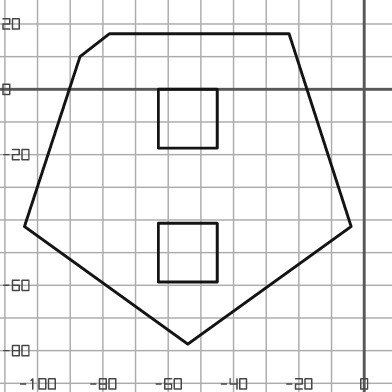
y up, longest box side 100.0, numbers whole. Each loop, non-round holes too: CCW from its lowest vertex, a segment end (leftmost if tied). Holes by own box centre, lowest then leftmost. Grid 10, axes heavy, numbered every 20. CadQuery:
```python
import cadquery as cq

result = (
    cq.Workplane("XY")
    .moveTo(-54.0, -78.0)
    .lineTo(-4.0, -42.0)
    .lineTo(-23.0, 17.0)
    .lineTo(-78.0, 17.0)
    .lineTo(-87.0, 10.0)
    .lineTo(-104.0, -42.0)
    .close()
    .moveTo(-63.0, -59.0)
    .lineTo(-45.0, -59.0)
    .lineTo(-45.0, -41.0)
    .lineTo(-63.0, -41.0)
    .close()
    .moveTo(-63.0, -18.0)
    .lineTo(-45.0, -18.0)
    .lineTo(-45.0, 0.0)
    .lineTo(-63.0, 0.0)
    .close()
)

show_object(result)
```